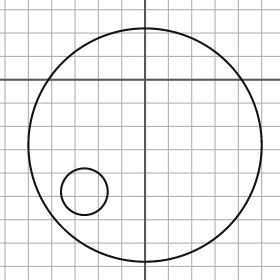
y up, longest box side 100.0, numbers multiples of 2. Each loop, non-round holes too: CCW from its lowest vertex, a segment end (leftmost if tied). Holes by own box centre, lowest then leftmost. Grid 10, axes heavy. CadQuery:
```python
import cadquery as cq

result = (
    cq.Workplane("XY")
    .moveTo(0.0, -28.0)
    .circle(50.0)
    .moveTo(-26.0, -48.0)
    .circle(10.0)
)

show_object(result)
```